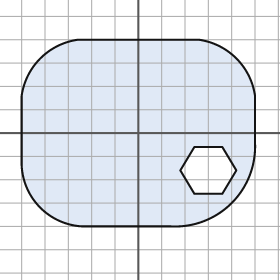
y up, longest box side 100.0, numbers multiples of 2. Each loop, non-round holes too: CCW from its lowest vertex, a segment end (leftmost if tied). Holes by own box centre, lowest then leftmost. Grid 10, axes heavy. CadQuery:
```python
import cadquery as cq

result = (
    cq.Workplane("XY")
    .moveTo(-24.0, -40.0)
    .lineTo(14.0, -40.0)
    .threePointArc((40.0, -30.0), (50.0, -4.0))
    .lineTo(50.0, 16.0)
    .threePointArc((42.0, 32.0), (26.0, 40.0))
    .lineTo(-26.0, 40.0)
    .threePointArc((-42.0, 32.0), (-50.0, 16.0))
    .lineTo(-50.0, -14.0)
    .threePointArc((-42.0, -32.0), (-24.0, -40.0))
    .close()
    .moveTo(24.0, -26.0)
    .lineTo(36.0, -26.0)
    .lineTo(42.0, -16.0)
    .lineTo(36.0, -6.0)
    .lineTo(24.0, -6.0)
    .lineTo(18.0, -16.0)
    .close()
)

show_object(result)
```